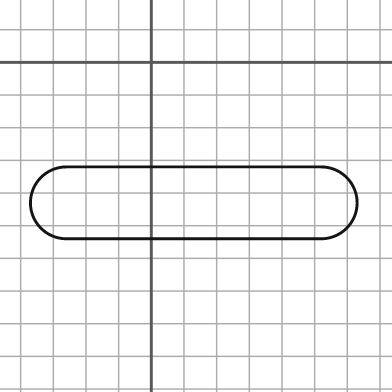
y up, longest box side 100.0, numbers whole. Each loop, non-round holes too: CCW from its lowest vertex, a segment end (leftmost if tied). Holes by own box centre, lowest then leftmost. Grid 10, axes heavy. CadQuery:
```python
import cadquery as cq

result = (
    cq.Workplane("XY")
    .moveTo(-26.0, -54.0)
    .lineTo(52.0, -54.0)
    .threePointArc((63.0, -43.0), (52.0, -32.0))
    .lineTo(-26.0, -32.0)
    .threePointArc((-37.0, -43.0), (-26.0, -54.0))
    .close()
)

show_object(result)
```